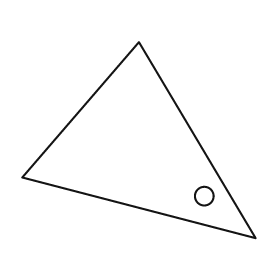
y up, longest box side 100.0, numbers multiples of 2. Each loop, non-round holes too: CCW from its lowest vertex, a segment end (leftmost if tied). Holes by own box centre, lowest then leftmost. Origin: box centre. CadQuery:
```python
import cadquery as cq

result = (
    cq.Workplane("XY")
    .moveTo(50.0, -42.0)
    .lineTo(0.0, 42.0)
    .lineTo(-50.0, -16.0)
    .close()
    .moveTo(28.0, -24.0)
    .circle(4.0)
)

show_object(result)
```